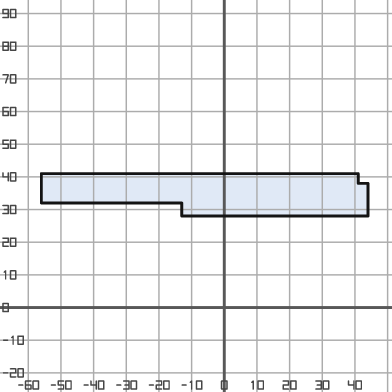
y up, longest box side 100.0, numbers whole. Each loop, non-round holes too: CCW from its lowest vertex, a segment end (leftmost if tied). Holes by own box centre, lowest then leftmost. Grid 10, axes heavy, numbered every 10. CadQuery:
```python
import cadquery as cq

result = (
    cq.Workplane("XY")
    .moveTo(-13.0, 28.0)
    .lineTo(44.0, 28.0)
    .lineTo(44.0, 38.0)
    .lineTo(41.0, 38.0)
    .lineTo(41.0, 41.0)
    .lineTo(-56.0, 41.0)
    .lineTo(-56.0, 32.0)
    .lineTo(-13.0, 32.0)
    .close()
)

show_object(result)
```